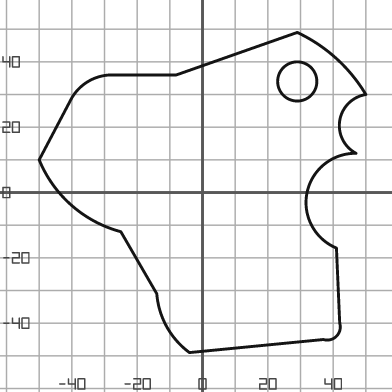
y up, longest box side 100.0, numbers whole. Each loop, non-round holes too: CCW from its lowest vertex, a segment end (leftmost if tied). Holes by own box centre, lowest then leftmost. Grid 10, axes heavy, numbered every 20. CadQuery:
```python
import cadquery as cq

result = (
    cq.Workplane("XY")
    .moveTo(-4.0, -49.0)
    .lineTo(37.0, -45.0)
    .threePointArc((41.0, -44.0), (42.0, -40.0))
    .lineTo(41.0, -17.0)
    .threePointArc((32.0, 0.0), (47.0, 12.0))
    .threePointArc((42.0, 22.0), (50.0, 30.0))
    .threePointArc((41.0, 41.0), (29.0, 49.0))
    .lineTo(-8.0, 36.0)
    .lineTo(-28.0, 36.0)
    .threePointArc((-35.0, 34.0), (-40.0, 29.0))
    .lineTo(-50.0, 10.0)
    .threePointArc((-40.0, -4.0), (-25.0, -12.0))
    .lineTo(-14.0, -31.0)
    .threePointArc((-11.0, -41.0), (-4.0, -49.0))
    .close()
    .moveTo(29.0, 34.0)
    .circle(6.0)
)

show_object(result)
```